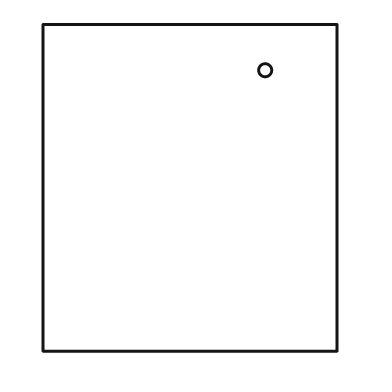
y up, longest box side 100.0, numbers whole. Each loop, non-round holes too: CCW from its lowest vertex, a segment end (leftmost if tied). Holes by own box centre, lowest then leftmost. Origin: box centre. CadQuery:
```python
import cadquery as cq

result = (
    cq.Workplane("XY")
    .moveTo(-45.0, -50.0)
    .lineTo(45.0, -50.0)
    .lineTo(45.0, 50.0)
    .lineTo(-45.0, 50.0)
    .close()
    .moveTo(23.0, 36.0)
    .circle(2.0)
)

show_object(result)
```